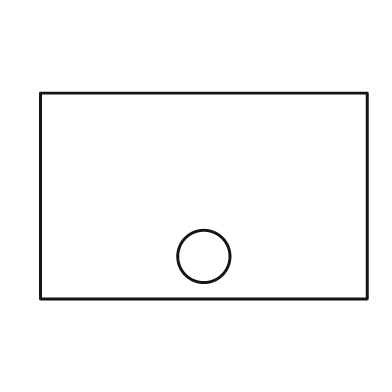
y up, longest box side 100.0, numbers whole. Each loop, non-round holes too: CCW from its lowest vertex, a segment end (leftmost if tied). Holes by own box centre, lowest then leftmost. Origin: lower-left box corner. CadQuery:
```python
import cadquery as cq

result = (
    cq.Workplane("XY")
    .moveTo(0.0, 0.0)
    .lineTo(100.0, 0.0)
    .lineTo(100.0, 63.0)
    .lineTo(0.0, 63.0)
    .close()
    .moveTo(50.0, 13.0)
    .circle(8.0)
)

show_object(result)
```